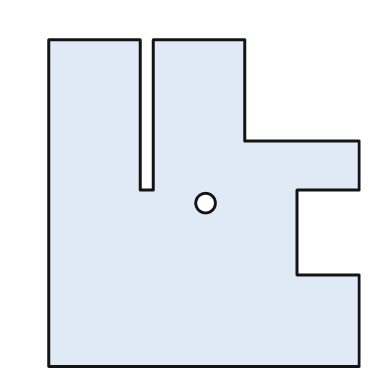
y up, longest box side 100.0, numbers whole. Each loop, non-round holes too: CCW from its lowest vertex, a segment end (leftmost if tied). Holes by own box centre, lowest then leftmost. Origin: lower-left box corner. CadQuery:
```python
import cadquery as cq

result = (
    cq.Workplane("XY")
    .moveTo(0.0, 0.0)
    .lineTo(95.0, 0.0)
    .lineTo(95.0, 28.0)
    .lineTo(76.0, 28.0)
    .lineTo(76.0, 54.0)
    .lineTo(95.0, 54.0)
    .lineTo(95.0, 69.0)
    .lineTo(60.0, 69.0)
    .lineTo(60.0, 100.0)
    .lineTo(32.0, 100.0)
    .lineTo(32.0, 54.0)
    .lineTo(28.0, 54.0)
    .lineTo(28.0, 100.0)
    .lineTo(0.0, 100.0)
    .close()
    .moveTo(48.0, 50.0)
    .circle(3.0)
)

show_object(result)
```